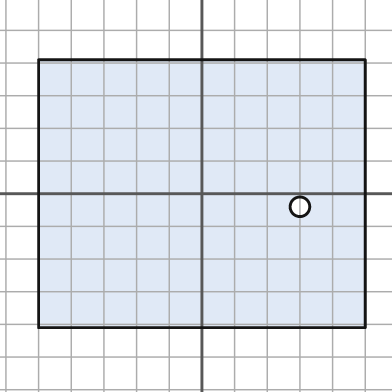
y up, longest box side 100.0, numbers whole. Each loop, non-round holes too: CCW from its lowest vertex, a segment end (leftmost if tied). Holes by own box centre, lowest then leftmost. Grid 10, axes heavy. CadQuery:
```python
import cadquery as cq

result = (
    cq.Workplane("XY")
    .moveTo(-50.0, -41.0)
    .lineTo(50.0, -41.0)
    .lineTo(50.0, 41.0)
    .lineTo(-50.0, 41.0)
    .close()
    .moveTo(30.0, -4.0)
    .circle(3.0)
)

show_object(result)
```